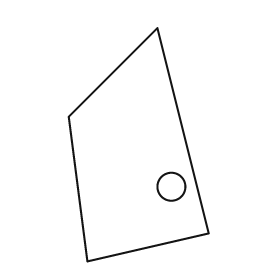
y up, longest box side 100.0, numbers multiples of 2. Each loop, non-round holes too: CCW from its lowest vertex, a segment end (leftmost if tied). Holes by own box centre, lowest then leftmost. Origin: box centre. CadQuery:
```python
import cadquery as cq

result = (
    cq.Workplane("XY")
    .moveTo(-22.0, -50.0)
    .lineTo(30.0, -38.0)
    .lineTo(8.0, 50.0)
    .lineTo(-30.0, 12.0)
    .close()
    .moveTo(14.0, -18.0)
    .circle(6.0)
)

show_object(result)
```